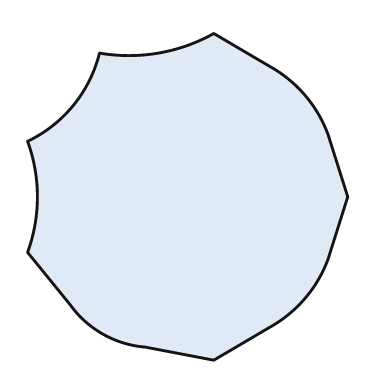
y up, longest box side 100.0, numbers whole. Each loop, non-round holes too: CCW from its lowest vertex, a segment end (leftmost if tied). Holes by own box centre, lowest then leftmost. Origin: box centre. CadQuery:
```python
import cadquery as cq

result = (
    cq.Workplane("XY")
    .moveTo(8.0, -50.0)
    .lineTo(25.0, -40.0)
    .threePointArc((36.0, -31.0), (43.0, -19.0))
    .lineTo(49.0, 0.0)
    .lineTo(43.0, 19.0)
    .threePointArc((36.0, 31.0), (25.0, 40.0))
    .lineTo(8.0, 50.0)
    .threePointArc((-9.0, 44.0), (-27.0, 44.0))
    .threePointArc((-35.0, 28.0), (-49.0, 17.0))
    .threePointArc((-46.0, 0.0), (-49.0, -17.0))
    .lineTo(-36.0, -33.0)
    .threePointArc((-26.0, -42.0), (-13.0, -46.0))
    .close()
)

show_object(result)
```